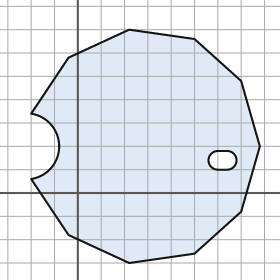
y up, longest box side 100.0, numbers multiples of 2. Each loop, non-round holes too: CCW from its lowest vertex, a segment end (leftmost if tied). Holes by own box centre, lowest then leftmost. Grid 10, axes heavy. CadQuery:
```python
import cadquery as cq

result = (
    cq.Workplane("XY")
    .moveTo(22.0, -30.0)
    .lineTo(50.0, -26.0)
    .lineTo(70.0, -8.0)
    .lineTo(78.0, 20.0)
    .lineTo(70.0, 48.0)
    .lineTo(50.0, 66.0)
    .lineTo(22.0, 70.0)
    .lineTo(-4.0, 58.0)
    .lineTo(-20.0, 34.0)
    .threePointArc((-8.0, 20.0), (-20.0, 6.0))
    .lineTo(-4.0, -18.0)
    .close()
    .moveTo(60.0, 10.0)
    .lineTo(64.0, 10.0)
    .threePointArc((68.0, 14.0), (64.0, 18.0))
    .lineTo(60.0, 18.0)
    .threePointArc((56.0, 14.0), (60.0, 10.0))
    .close()
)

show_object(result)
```